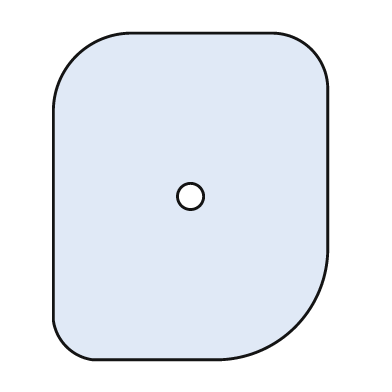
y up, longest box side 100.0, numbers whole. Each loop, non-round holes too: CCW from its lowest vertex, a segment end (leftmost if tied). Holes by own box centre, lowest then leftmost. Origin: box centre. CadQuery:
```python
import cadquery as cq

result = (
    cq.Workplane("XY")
    .moveTo(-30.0, -50.0)
    .lineTo(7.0, -50.0)
    .threePointArc((32.0, -40.0), (42.0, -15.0))
    .lineTo(42.0, 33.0)
    .threePointArc((37.0, 45.0), (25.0, 50.0))
    .lineTo(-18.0, 50.0)
    .threePointArc((-35.0, 43.0), (-42.0, 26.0))
    .lineTo(-42.0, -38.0)
    .threePointArc((-38.0, -46.0), (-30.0, -50.0))
    .close()
    .moveTo(0.0, 0.0)
    .circle(4.0)
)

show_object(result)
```